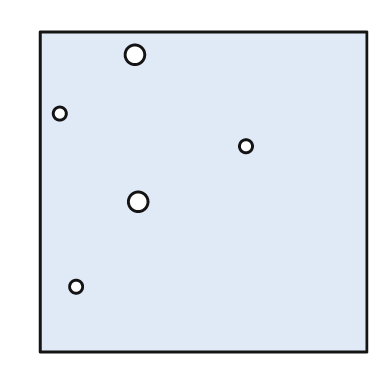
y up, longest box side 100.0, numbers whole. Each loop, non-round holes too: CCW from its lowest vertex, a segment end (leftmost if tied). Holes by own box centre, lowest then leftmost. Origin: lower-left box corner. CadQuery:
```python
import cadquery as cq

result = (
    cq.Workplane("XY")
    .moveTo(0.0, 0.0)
    .lineTo(100.0, 0.0)
    .lineTo(100.0, 98.0)
    .lineTo(0.0, 98.0)
    .close()
    .moveTo(11.0, 20.0)
    .circle(2.0)
    .moveTo(30.0, 46.0)
    .circle(3.0)
    .moveTo(63.0, 63.0)
    .circle(2.0)
    .moveTo(6.0, 73.0)
    .circle(2.0)
    .moveTo(29.0, 91.0)
    .circle(3.0)
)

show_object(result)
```